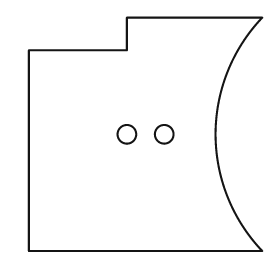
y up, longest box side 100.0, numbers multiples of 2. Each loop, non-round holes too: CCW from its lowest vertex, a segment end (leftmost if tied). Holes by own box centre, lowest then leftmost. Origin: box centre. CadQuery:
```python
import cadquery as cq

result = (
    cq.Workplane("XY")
    .moveTo(-50.0, -50.0)
    .lineTo(50.0, -50.0)
    .threePointArc((30.0, 0.0), (50.0, 50.0))
    .lineTo(-8.0, 50.0)
    .lineTo(-8.0, 36.0)
    .lineTo(-50.0, 36.0)
    .close()
    .moveTo(-8.0, 0.0)
    .circle(4.0)
    .moveTo(8.0, 0.0)
    .circle(4.0)
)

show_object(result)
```